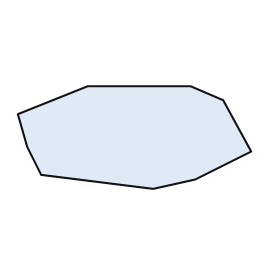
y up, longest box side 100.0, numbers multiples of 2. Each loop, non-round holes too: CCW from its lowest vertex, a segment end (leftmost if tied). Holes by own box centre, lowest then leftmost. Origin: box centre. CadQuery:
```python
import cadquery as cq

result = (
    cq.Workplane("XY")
    .moveTo(8.0, -22.0)
    .lineTo(26.0, -18.0)
    .lineTo(50.0, -6.0)
    .lineTo(38.0, 16.0)
    .lineTo(24.0, 22.0)
    .lineTo(-20.0, 22.0)
    .lineTo(-50.0, 10.0)
    .lineTo(-46.0, -4.0)
    .lineTo(-40.0, -16.0)
    .close()
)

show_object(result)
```